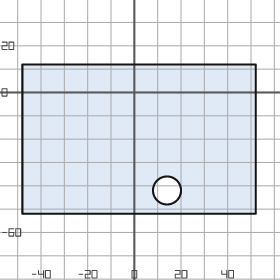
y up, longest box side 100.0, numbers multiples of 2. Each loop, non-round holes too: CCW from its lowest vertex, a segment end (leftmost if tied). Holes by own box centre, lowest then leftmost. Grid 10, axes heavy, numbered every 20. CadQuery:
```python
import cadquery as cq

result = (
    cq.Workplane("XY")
    .moveTo(-48.0, -52.0)
    .lineTo(52.0, -52.0)
    .lineTo(52.0, 12.0)
    .lineTo(-48.0, 12.0)
    .close()
    .moveTo(14.0, -42.0)
    .circle(6.0)
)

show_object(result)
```